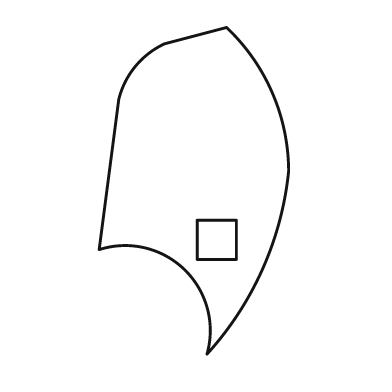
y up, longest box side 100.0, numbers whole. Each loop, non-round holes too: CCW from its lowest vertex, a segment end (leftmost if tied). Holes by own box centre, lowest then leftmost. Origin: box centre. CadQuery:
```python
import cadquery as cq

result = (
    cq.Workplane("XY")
    .moveTo(4.0, -50.0)
    .threePointArc((21.0, -24.0), (29.0, 6.0))
    .threePointArc((24.0, 30.0), (10.0, 50.0))
    .lineTo(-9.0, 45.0)
    .threePointArc((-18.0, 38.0), (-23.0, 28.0))
    .lineTo(-29.0, -18.0)
    .threePointArc((-3.0, -24.0), (4.0, -50.0))
    .close()
    .moveTo(1.0, -21.0)
    .lineTo(13.0, -21.0)
    .lineTo(13.0, -9.0)
    .lineTo(1.0, -9.0)
    .close()
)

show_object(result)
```